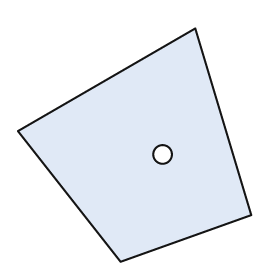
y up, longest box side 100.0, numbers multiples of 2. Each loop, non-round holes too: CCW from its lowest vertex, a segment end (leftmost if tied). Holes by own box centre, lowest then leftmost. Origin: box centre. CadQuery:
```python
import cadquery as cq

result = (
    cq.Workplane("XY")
    .moveTo(-6.0, -50.0)
    .lineTo(50.0, -30.0)
    .lineTo(26.0, 50.0)
    .lineTo(-50.0, 6.0)
    .close()
    .moveTo(12.0, -4.0)
    .circle(4.0)
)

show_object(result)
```